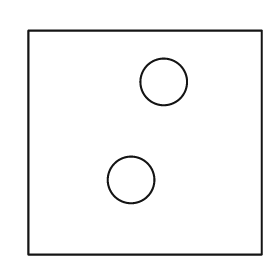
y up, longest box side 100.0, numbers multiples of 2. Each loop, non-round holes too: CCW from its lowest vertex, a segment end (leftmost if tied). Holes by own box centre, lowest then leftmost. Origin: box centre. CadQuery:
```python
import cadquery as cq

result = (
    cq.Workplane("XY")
    .moveTo(-50.0, -48.0)
    .lineTo(50.0, -48.0)
    .lineTo(50.0, 48.0)
    .lineTo(-50.0, 48.0)
    .close()
    .moveTo(-6.0, -16.0)
    .circle(10.0)
    .moveTo(8.0, 26.0)
    .circle(10.0)
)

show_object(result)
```